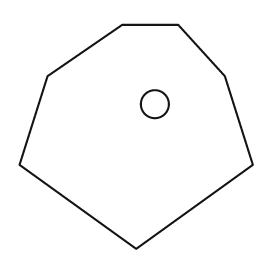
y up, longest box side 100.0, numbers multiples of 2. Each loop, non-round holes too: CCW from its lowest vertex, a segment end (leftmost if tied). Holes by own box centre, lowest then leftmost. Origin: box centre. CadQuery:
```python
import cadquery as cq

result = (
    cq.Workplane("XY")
    .moveTo(0.0, -48.0)
    .lineTo(50.0, -12.0)
    .lineTo(38.0, 26.0)
    .lineTo(18.0, 48.0)
    .lineTo(-6.0, 48.0)
    .lineTo(-38.0, 26.0)
    .lineTo(-50.0, -12.0)
    .close()
    .moveTo(8.0, 14.0)
    .circle(6.0)
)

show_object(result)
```